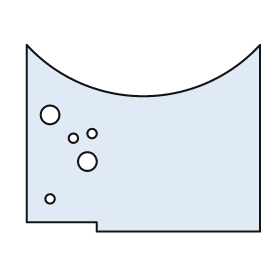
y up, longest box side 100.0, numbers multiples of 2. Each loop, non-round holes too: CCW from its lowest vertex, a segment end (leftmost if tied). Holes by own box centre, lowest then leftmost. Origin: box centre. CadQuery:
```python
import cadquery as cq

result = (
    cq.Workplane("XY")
    .moveTo(-20.0, -40.0)
    .lineTo(50.0, -40.0)
    .lineTo(50.0, 40.0)
    .threePointArc((0.0, 18.0), (-50.0, 40.0))
    .lineTo(-50.0, -36.0)
    .lineTo(-20.0, -36.0)
    .close()
    .moveTo(-40.0, -26.0)
    .circle(2.0)
    .moveTo(-24.0, -10.0)
    .circle(4.0)
    .moveTo(-30.0, 0.0)
    .circle(2.0)
    .moveTo(-22.0, 2.0)
    .circle(2.0)
    .moveTo(-40.0, 10.0)
    .circle(4.0)
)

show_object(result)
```